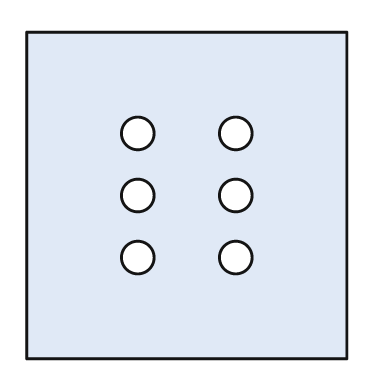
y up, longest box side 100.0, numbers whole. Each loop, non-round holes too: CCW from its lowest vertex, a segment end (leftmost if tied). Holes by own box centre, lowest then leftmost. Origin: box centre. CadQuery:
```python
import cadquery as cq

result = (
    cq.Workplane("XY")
    .moveTo(-49.0, -50.0)
    .lineTo(49.0, -50.0)
    .lineTo(49.0, 50.0)
    .lineTo(-49.0, 50.0)
    .close()
    .moveTo(-15.0, -19.0)
    .circle(5.0)
    .moveTo(15.0, -19.0)
    .circle(5.0)
    .moveTo(-15.0, 0.0)
    .circle(5.0)
    .moveTo(15.0, 0.0)
    .circle(5.0)
    .moveTo(-15.0, 19.0)
    .circle(5.0)
    .moveTo(15.0, 19.0)
    .circle(5.0)
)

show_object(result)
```